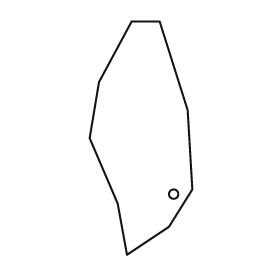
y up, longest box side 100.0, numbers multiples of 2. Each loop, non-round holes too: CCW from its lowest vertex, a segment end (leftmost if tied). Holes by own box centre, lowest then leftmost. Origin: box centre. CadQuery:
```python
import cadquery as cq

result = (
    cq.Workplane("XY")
    .moveTo(-6.0, -50.0)
    .lineTo(12.0, -38.0)
    .lineTo(22.0, -22.0)
    .lineTo(20.0, 12.0)
    .lineTo(8.0, 50.0)
    .lineTo(-4.0, 50.0)
    .lineTo(-18.0, 24.0)
    .lineTo(-22.0, 0.0)
    .lineTo(-10.0, -28.0)
    .close()
    .moveTo(14.0, -24.0)
    .circle(2.0)
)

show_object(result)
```